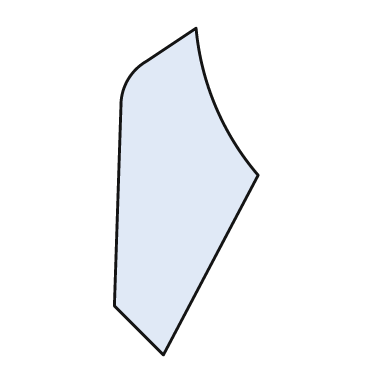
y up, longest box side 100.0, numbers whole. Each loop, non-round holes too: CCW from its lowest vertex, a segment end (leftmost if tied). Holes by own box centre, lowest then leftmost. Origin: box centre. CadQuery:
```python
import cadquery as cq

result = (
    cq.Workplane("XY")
    .moveTo(-7.0, -50.0)
    .lineTo(22.0, 5.0)
    .threePointArc((9.0, 26.0), (3.0, 50.0))
    .lineTo(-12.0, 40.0)
    .threePointArc((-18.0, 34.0), (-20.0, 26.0))
    .lineTo(-22.0, -35.0)
    .close()
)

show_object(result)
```